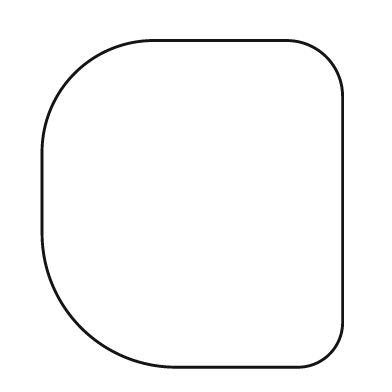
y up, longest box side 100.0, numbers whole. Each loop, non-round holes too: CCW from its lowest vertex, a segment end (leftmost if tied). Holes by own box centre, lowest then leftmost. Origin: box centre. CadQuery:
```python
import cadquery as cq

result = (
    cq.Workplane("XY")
    .moveTo(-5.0, -50.0)
    .lineTo(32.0, -50.0)
    .threePointArc((42.0, -46.0), (46.0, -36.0))
    .lineTo(46.0, 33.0)
    .threePointArc((41.0, 45.0), (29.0, 50.0))
    .lineTo(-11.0, 50.0)
    .threePointArc((-36.0, 40.0), (-46.0, 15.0))
    .lineTo(-46.0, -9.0)
    .threePointArc((-34.0, -38.0), (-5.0, -50.0))
    .close()
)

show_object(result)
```